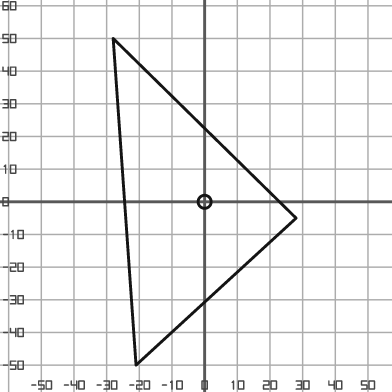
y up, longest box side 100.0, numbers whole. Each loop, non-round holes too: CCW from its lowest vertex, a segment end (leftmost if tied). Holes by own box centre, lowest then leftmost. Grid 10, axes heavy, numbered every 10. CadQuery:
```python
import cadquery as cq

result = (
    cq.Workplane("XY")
    .moveTo(-21.0, -50.0)
    .lineTo(28.0, -5.0)
    .lineTo(-28.0, 50.0)
    .close()
    .moveTo(0.0, 0.0)
    .circle(2.0)
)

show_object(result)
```